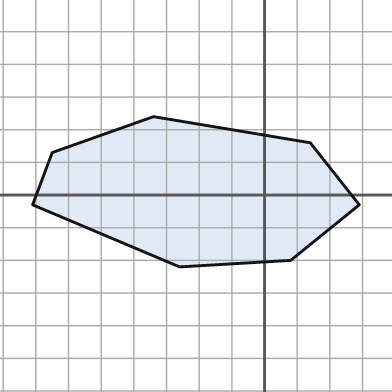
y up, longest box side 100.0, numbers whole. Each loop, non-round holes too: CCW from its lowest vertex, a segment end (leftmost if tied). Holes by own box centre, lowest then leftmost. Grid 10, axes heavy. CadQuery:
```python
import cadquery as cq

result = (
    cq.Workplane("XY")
    .moveTo(-26.0, -22.0)
    .lineTo(8.0, -20.0)
    .lineTo(29.0, -3.0)
    .lineTo(14.0, 16.0)
    .lineTo(-34.0, 24.0)
    .lineTo(-65.0, 13.0)
    .lineTo(-71.0, -3.0)
    .close()
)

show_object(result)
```